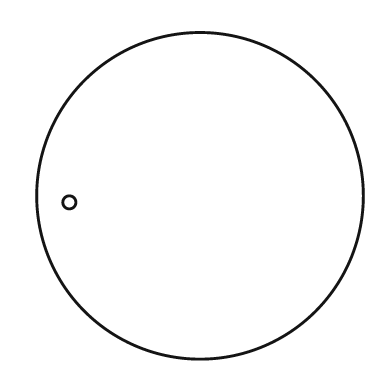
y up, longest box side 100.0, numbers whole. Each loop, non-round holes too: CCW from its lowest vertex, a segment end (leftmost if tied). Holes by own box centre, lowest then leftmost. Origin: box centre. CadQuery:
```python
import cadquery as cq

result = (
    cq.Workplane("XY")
    .moveTo(0.0, 0.0)
    .circle(50.0)
    .moveTo(-40.0, -2.0)
    .circle(2.0)
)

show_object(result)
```